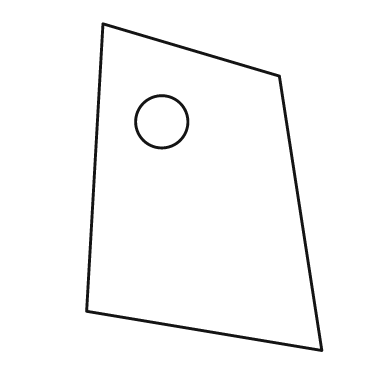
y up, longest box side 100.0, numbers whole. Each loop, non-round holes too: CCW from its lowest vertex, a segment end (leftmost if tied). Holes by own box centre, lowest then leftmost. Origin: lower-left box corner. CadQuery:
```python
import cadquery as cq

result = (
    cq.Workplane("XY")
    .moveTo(72.0, 0.0)
    .lineTo(59.0, 84.0)
    .lineTo(5.0, 100.0)
    .lineTo(0.0, 12.0)
    .close()
    .moveTo(23.0, 70.0)
    .circle(8.0)
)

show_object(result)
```